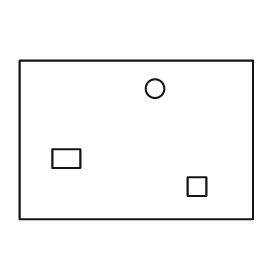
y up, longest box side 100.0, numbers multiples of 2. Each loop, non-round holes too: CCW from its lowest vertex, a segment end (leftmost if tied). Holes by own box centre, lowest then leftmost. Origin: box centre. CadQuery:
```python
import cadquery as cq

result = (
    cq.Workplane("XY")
    .moveTo(-50.0, -34.0)
    .lineTo(50.0, -34.0)
    .lineTo(50.0, 34.0)
    .lineTo(-50.0, 34.0)
    .close()
    .moveTo(22.0, -24.0)
    .lineTo(30.0, -24.0)
    .lineTo(30.0, -16.0)
    .lineTo(22.0, -16.0)
    .close()
    .moveTo(-36.0, -12.0)
    .lineTo(-24.0, -12.0)
    .lineTo(-24.0, -4.0)
    .lineTo(-36.0, -4.0)
    .close()
    .moveTo(8.0, 22.0)
    .circle(4.0)
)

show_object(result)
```